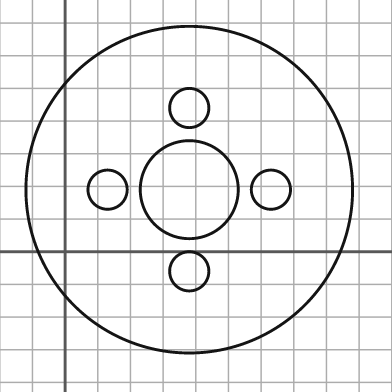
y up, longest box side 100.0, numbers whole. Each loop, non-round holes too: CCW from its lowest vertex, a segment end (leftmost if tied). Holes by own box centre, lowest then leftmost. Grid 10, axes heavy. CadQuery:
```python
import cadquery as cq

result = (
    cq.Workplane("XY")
    .moveTo(38.0, 19.0)
    .circle(50.0)
    .moveTo(38.0, -6.0)
    .circle(6.0)
    .moveTo(13.0, 19.0)
    .circle(6.0)
    .moveTo(38.0, 19.0)
    .circle(15.0)
    .moveTo(63.0, 19.0)
    .circle(6.0)
    .moveTo(38.0, 44.0)
    .circle(6.0)
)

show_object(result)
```